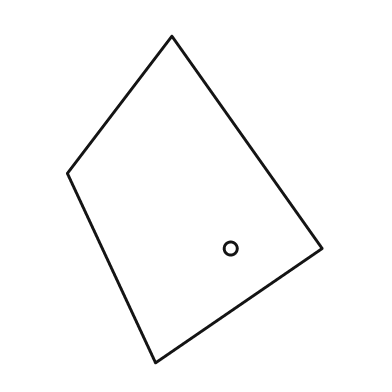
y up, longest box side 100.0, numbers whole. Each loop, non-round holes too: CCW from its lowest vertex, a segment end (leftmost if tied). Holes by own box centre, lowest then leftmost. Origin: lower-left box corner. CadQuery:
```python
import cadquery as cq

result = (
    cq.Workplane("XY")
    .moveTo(27.0, 0.0)
    .lineTo(78.0, 35.0)
    .lineTo(32.0, 100.0)
    .lineTo(0.0, 58.0)
    .close()
    .moveTo(50.0, 35.0)
    .circle(2.0)
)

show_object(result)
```